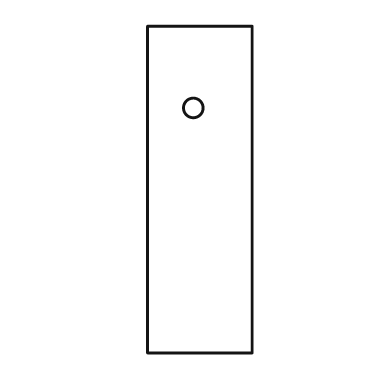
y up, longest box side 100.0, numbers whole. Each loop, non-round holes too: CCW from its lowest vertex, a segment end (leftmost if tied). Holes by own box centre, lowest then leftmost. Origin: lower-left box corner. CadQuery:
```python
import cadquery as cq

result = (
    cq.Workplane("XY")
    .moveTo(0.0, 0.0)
    .lineTo(32.0, 0.0)
    .lineTo(32.0, 100.0)
    .lineTo(0.0, 100.0)
    .close()
    .moveTo(14.0, 75.0)
    .circle(3.0)
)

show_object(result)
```